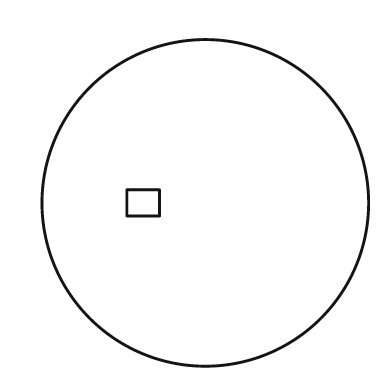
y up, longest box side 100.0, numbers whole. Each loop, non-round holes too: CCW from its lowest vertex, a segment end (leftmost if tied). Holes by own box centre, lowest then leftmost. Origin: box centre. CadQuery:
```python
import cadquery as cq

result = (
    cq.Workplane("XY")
    .moveTo(0.0, 0.0)
    .circle(50.0)
    .moveTo(-24.0, -4.0)
    .lineTo(-14.0, -4.0)
    .lineTo(-14.0, 4.0)
    .lineTo(-24.0, 4.0)
    .close()
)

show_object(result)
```